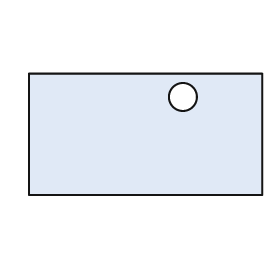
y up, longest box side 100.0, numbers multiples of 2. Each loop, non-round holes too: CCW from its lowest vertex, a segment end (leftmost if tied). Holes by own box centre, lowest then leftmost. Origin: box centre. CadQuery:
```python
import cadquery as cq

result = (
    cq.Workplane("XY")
    .moveTo(-50.0, -26.0)
    .lineTo(50.0, -26.0)
    .lineTo(50.0, 26.0)
    .lineTo(-50.0, 26.0)
    .close()
    .moveTo(16.0, 16.0)
    .circle(6.0)
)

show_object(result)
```